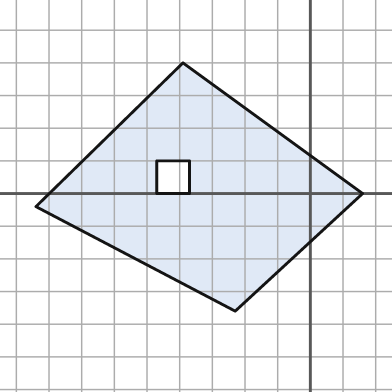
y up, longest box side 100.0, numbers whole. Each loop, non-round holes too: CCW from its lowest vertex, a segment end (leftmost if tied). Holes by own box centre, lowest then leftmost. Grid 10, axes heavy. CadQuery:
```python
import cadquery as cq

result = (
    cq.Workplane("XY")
    .moveTo(-23.0, -36.0)
    .lineTo(16.0, 0.0)
    .lineTo(-39.0, 40.0)
    .lineTo(-84.0, -4.0)
    .close()
    .moveTo(-47.0, 0.0)
    .lineTo(-37.0, 0.0)
    .lineTo(-37.0, 10.0)
    .lineTo(-47.0, 10.0)
    .close()
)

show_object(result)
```